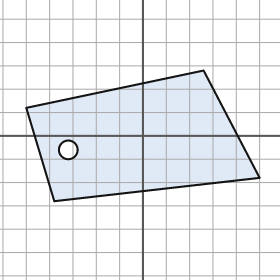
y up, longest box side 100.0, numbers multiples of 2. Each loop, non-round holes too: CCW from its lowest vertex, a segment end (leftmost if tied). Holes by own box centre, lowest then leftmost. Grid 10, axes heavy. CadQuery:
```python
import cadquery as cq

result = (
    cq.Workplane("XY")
    .moveTo(-38.0, -28.0)
    .lineTo(50.0, -18.0)
    .lineTo(26.0, 28.0)
    .lineTo(-50.0, 12.0)
    .close()
    .moveTo(-32.0, -6.0)
    .circle(4.0)
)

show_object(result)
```